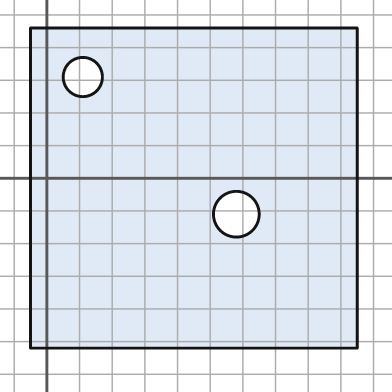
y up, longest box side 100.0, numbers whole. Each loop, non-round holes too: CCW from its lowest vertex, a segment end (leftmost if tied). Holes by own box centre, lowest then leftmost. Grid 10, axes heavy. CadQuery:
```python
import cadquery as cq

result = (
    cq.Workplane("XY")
    .moveTo(-5.0, -52.0)
    .lineTo(95.0, -52.0)
    .lineTo(95.0, 46.0)
    .lineTo(-5.0, 46.0)
    .close()
    .moveTo(58.0, -11.0)
    .circle(7.0)
    .moveTo(11.0, 31.0)
    .circle(6.0)
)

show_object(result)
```